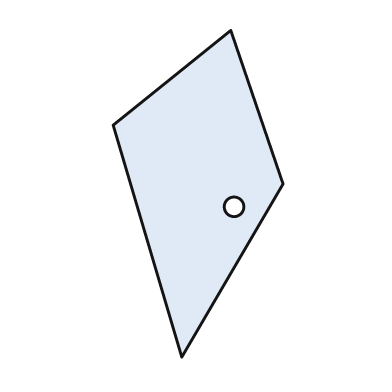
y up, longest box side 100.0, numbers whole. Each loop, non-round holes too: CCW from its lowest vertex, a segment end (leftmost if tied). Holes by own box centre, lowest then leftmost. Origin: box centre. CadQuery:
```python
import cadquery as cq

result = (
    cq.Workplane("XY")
    .moveTo(-5.0, -50.0)
    .lineTo(26.0, 3.0)
    .lineTo(10.0, 50.0)
    .lineTo(-26.0, 21.0)
    .close()
    .moveTo(11.0, -4.0)
    .circle(3.0)
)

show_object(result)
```